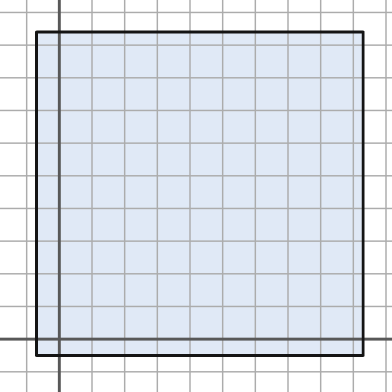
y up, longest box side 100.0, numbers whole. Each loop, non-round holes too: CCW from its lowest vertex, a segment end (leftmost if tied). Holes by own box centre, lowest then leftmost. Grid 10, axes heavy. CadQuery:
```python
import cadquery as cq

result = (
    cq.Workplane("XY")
    .moveTo(-7.0, -5.0)
    .lineTo(93.0, -5.0)
    .lineTo(93.0, 94.0)
    .lineTo(-7.0, 94.0)
    .close()
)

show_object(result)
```